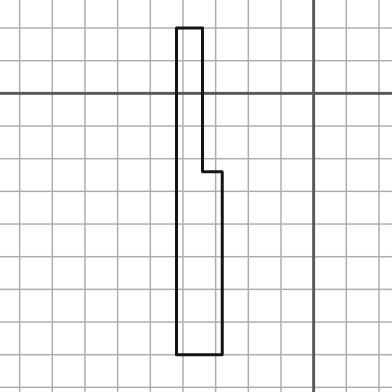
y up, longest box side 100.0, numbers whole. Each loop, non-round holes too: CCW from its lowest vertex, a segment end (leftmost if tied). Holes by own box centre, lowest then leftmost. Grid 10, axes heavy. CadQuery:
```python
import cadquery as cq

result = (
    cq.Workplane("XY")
    .moveTo(-42.0, -80.0)
    .lineTo(-28.0, -80.0)
    .lineTo(-28.0, -24.0)
    .lineTo(-34.0, -24.0)
    .lineTo(-34.0, 20.0)
    .lineTo(-42.0, 20.0)
    .close()
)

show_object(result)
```